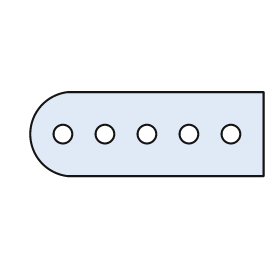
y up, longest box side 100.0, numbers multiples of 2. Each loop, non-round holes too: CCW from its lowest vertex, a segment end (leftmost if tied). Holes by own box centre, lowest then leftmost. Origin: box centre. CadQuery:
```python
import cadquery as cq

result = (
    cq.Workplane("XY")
    .moveTo(-34.0, -18.0)
    .lineTo(50.0, -18.0)
    .lineTo(50.0, 18.0)
    .lineTo(-34.0, 18.0)
    .threePointArc((-50.0, 0.0), (-34.0, -18.0))
    .close()
    .moveTo(-36.0, 0.0)
    .circle(4.0)
    .moveTo(-18.0, 0.0)
    .circle(4.0)
    .moveTo(0.0, 0.0)
    .circle(4.0)
    .moveTo(18.0, 0.0)
    .circle(4.0)
    .moveTo(36.0, 0.0)
    .circle(4.0)
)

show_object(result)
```